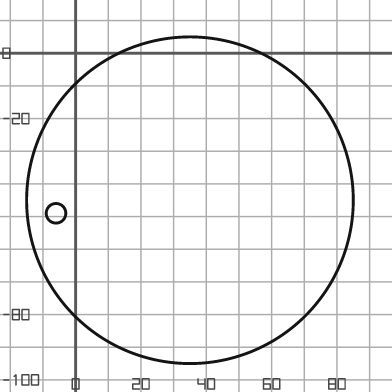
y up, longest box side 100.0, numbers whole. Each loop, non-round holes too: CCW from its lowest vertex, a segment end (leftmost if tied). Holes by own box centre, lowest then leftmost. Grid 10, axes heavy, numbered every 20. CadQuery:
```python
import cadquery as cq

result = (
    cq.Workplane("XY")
    .moveTo(35.0, -45.0)
    .circle(50.0)
    .moveTo(-6.0, -49.0)
    .circle(3.0)
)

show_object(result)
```